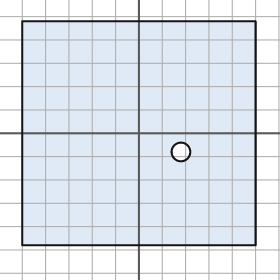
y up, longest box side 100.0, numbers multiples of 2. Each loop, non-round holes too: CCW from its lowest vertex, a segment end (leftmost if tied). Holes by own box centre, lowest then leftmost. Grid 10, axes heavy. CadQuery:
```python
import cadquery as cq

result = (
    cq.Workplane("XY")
    .moveTo(-50.0, -48.0)
    .lineTo(50.0, -48.0)
    .lineTo(50.0, 48.0)
    .lineTo(-50.0, 48.0)
    .close()
    .moveTo(18.0, -8.0)
    .circle(4.0)
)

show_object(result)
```